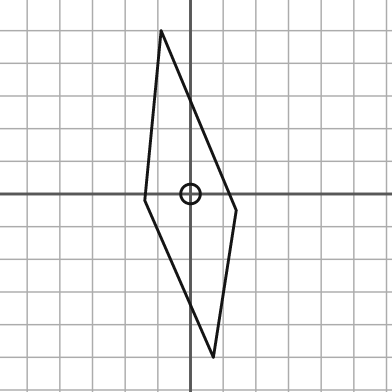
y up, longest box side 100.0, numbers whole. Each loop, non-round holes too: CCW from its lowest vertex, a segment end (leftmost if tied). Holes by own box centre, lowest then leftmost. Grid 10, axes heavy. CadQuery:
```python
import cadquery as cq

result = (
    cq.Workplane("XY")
    .moveTo(7.0, -50.0)
    .lineTo(14.0, -5.0)
    .lineTo(-9.0, 50.0)
    .lineTo(-14.0, -2.0)
    .close()
    .moveTo(0.0, 0.0)
    .circle(3.0)
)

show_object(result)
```